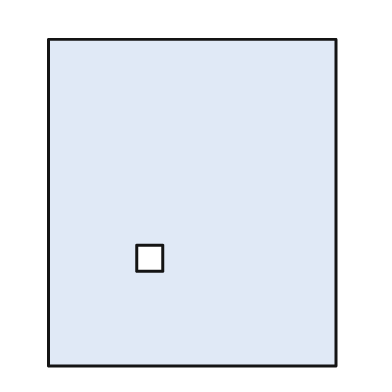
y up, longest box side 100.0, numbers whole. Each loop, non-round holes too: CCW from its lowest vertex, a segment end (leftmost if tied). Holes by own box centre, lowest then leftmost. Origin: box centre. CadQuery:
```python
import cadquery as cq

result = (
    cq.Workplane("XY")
    .moveTo(-44.0, -50.0)
    .lineTo(44.0, -50.0)
    .lineTo(44.0, 50.0)
    .lineTo(-44.0, 50.0)
    .close()
    .moveTo(-17.0, -21.0)
    .lineTo(-9.0, -21.0)
    .lineTo(-9.0, -13.0)
    .lineTo(-17.0, -13.0)
    .close()
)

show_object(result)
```